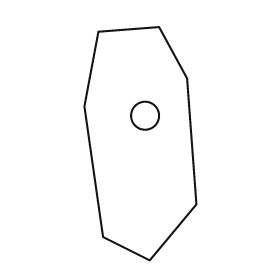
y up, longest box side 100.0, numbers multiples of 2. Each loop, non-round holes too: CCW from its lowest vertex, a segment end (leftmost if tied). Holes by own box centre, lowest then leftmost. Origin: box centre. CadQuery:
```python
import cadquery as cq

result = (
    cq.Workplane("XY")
    .moveTo(4.0, -50.0)
    .lineTo(24.0, -26.0)
    .lineTo(20.0, 28.0)
    .lineTo(8.0, 50.0)
    .lineTo(-18.0, 48.0)
    .lineTo(-24.0, 16.0)
    .lineTo(-16.0, -40.0)
    .close()
    .moveTo(2.0, 12.0)
    .circle(6.0)
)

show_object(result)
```